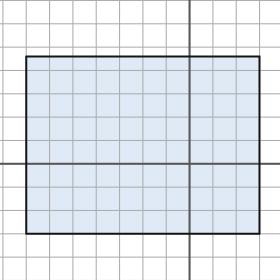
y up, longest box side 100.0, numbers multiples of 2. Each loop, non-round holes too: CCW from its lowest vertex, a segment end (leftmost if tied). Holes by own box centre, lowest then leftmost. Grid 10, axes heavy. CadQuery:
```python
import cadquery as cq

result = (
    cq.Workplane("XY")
    .moveTo(-70.0, -30.0)
    .lineTo(30.0, -30.0)
    .lineTo(30.0, 46.0)
    .lineTo(-70.0, 46.0)
    .close()
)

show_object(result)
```